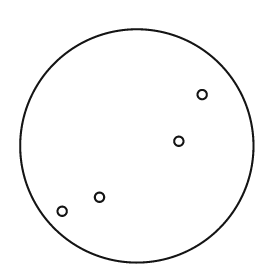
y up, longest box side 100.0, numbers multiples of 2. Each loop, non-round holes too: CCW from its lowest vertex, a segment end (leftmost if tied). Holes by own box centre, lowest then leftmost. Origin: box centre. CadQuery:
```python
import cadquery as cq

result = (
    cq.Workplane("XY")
    .moveTo(0.0, 0.0)
    .circle(50.0)
    .moveTo(-32.0, -28.0)
    .circle(2.0)
    .moveTo(-16.0, -22.0)
    .circle(2.0)
    .moveTo(18.0, 2.0)
    .circle(2.0)
    .moveTo(28.0, 22.0)
    .circle(2.0)
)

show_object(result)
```